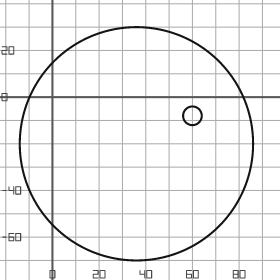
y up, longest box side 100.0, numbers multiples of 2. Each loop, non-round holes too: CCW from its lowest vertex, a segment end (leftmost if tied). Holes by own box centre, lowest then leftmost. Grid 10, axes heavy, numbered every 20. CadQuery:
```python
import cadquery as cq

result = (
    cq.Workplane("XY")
    .moveTo(36.0, -20.0)
    .circle(50.0)
    .moveTo(60.0, -8.0)
    .circle(4.0)
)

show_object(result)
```